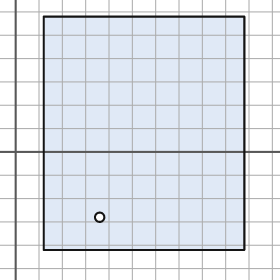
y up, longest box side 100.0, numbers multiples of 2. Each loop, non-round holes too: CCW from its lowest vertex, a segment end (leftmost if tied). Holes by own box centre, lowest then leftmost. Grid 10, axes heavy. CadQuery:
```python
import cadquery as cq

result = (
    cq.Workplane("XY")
    .moveTo(12.0, -42.0)
    .lineTo(98.0, -42.0)
    .lineTo(98.0, 58.0)
    .lineTo(12.0, 58.0)
    .close()
    .moveTo(36.0, -28.0)
    .circle(2.0)
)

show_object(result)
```